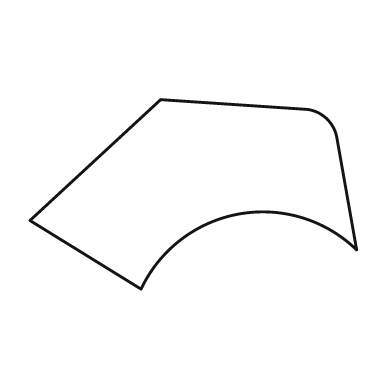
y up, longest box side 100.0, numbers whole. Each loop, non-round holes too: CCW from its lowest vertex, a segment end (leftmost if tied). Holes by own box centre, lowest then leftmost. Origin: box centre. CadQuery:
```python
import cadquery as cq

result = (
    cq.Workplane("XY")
    .moveTo(-16.0, -29.0)
    .threePointArc((14.0, -6.0), (50.0, -17.0))
    .lineTo(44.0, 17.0)
    .threePointArc((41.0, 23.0), (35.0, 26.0))
    .lineTo(-10.0, 29.0)
    .lineTo(-50.0, -8.0)
    .close()
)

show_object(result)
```